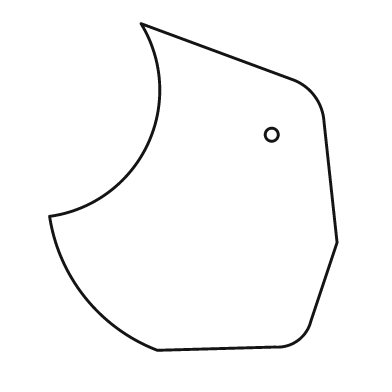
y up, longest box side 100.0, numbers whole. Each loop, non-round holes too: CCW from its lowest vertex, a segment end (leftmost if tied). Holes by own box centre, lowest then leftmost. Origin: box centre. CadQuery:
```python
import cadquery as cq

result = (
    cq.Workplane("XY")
    .moveTo(-11.0, -50.0)
    .lineTo(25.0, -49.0)
    .threePointArc((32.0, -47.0), (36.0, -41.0))
    .lineTo(44.0, -17.0)
    .lineTo(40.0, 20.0)
    .threePointArc((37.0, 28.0), (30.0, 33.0))
    .lineTo(-16.0, 50.0)
    .threePointArc((-14.0, 13.0), (-44.0, -9.0))
    .threePointArc((-33.0, -34.0), (-11.0, -50.0))
    .close()
    .moveTo(24.0, 16.0)
    .circle(2.0)
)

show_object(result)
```